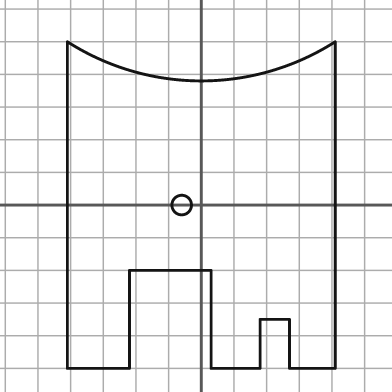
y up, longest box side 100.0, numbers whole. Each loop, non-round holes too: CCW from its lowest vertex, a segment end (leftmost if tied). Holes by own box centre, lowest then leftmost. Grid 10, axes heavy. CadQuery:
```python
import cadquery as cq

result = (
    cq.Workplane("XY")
    .moveTo(-41.0, -50.0)
    .lineTo(-22.0, -50.0)
    .lineTo(-22.0, -20.0)
    .lineTo(3.0, -20.0)
    .lineTo(3.0, -50.0)
    .lineTo(18.0, -50.0)
    .lineTo(18.0, -35.0)
    .lineTo(27.0, -35.0)
    .lineTo(27.0, -50.0)
    .lineTo(41.0, -50.0)
    .lineTo(41.0, 50.0)
    .threePointArc((0.0, 38.0), (-41.0, 50.0))
    .close()
    .moveTo(-6.0, 0.0)
    .circle(3.0)
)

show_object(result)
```